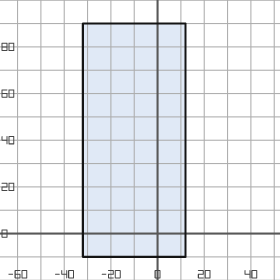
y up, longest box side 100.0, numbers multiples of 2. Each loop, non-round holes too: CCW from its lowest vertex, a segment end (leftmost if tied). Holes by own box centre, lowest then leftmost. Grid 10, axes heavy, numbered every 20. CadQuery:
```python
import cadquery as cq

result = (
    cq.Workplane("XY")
    .moveTo(-32.0, -10.0)
    .lineTo(12.0, -10.0)
    .lineTo(12.0, 90.0)
    .lineTo(-32.0, 90.0)
    .close()
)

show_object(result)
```